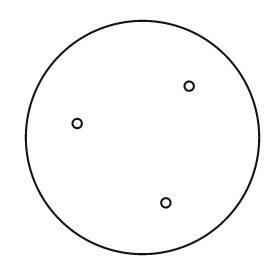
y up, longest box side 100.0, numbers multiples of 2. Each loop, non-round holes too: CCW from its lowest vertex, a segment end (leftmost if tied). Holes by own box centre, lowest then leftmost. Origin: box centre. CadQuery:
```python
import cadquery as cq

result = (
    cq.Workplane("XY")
    .moveTo(0.0, 0.0)
    .circle(50.0)
    .moveTo(10.0, -28.0)
    .circle(2.0)
    .moveTo(-28.0, 6.0)
    .circle(2.0)
    .moveTo(20.0, 22.0)
    .circle(2.0)
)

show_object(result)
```